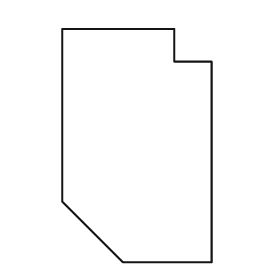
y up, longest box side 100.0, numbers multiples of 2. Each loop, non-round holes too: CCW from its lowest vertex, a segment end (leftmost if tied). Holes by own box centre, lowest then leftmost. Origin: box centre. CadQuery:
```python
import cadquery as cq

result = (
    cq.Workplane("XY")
    .moveTo(-6.0, -50.0)
    .lineTo(32.0, -50.0)
    .lineTo(32.0, 36.0)
    .lineTo(16.0, 36.0)
    .lineTo(16.0, 50.0)
    .lineTo(-32.0, 50.0)
    .lineTo(-32.0, -24.0)
    .close()
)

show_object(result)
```